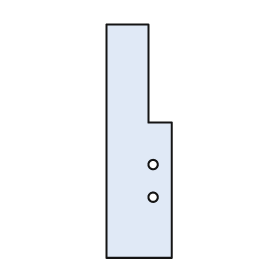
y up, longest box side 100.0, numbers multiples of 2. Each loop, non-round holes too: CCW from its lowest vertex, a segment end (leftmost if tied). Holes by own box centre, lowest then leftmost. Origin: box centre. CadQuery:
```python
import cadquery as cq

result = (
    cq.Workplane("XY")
    .moveTo(-14.0, -50.0)
    .lineTo(14.0, -50.0)
    .lineTo(14.0, 8.0)
    .lineTo(4.0, 8.0)
    .lineTo(4.0, 50.0)
    .lineTo(-14.0, 50.0)
    .close()
    .moveTo(6.0, -24.0)
    .circle(2.0)
    .moveTo(6.0, -10.0)
    .circle(2.0)
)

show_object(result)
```